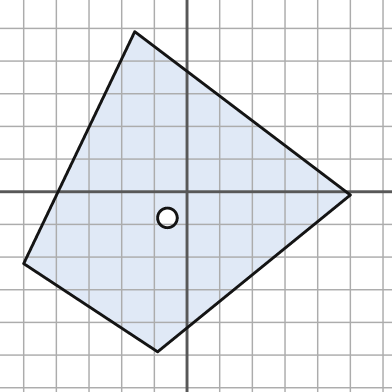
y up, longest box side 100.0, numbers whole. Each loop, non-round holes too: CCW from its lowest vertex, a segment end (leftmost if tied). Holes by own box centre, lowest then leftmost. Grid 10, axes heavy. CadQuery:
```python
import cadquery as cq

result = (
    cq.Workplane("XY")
    .moveTo(-9.0, -49.0)
    .lineTo(50.0, -1.0)
    .lineTo(-16.0, 49.0)
    .lineTo(-50.0, -22.0)
    .close()
    .moveTo(-6.0, -8.0)
    .circle(3.0)
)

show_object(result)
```